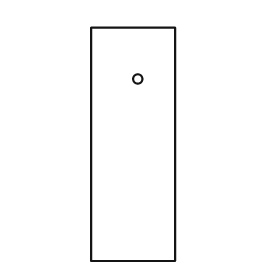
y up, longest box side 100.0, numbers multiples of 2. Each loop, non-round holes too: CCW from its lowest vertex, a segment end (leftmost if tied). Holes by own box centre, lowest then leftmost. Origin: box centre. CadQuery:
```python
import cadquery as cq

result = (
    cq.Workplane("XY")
    .moveTo(-18.0, -50.0)
    .lineTo(18.0, -50.0)
    .lineTo(18.0, 50.0)
    .lineTo(-18.0, 50.0)
    .close()
    .moveTo(2.0, 28.0)
    .circle(2.0)
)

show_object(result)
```